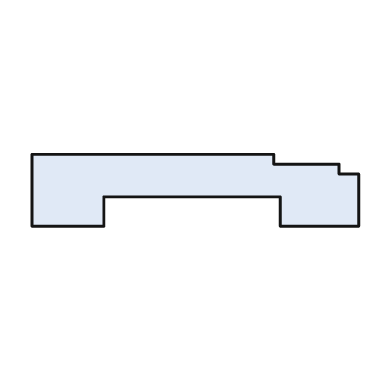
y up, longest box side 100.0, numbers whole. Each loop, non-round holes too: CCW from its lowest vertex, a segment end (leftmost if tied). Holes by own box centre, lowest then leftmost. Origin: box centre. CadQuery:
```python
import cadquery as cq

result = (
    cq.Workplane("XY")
    .moveTo(-50.0, -11.0)
    .lineTo(-28.0, -11.0)
    .lineTo(-28.0, -2.0)
    .lineTo(26.0, -2.0)
    .lineTo(26.0, -11.0)
    .lineTo(50.0, -11.0)
    .lineTo(50.0, 5.0)
    .lineTo(44.0, 5.0)
    .lineTo(44.0, 8.0)
    .lineTo(24.0, 8.0)
    .lineTo(24.0, 11.0)
    .lineTo(-50.0, 11.0)
    .close()
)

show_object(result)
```